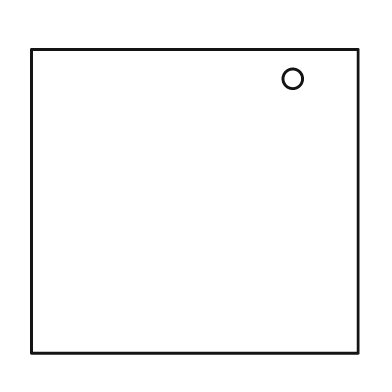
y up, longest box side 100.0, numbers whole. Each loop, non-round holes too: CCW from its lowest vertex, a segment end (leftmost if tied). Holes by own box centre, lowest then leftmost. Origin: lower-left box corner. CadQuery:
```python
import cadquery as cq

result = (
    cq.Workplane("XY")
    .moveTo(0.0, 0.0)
    .lineTo(100.0, 0.0)
    .lineTo(100.0, 93.0)
    .lineTo(0.0, 93.0)
    .close()
    .moveTo(80.0, 84.0)
    .circle(3.0)
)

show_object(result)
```